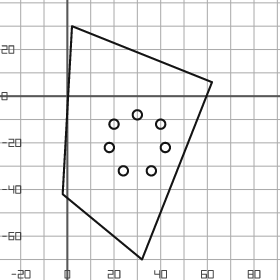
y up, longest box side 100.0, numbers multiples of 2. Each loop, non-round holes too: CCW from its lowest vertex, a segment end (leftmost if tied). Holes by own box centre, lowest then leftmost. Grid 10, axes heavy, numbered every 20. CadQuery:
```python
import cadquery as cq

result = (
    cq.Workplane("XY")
    .moveTo(32.0, -70.0)
    .lineTo(62.0, 6.0)
    .lineTo(2.0, 30.0)
    .lineTo(-2.0, -42.0)
    .close()
    .moveTo(24.0, -32.0)
    .circle(2.0)
    .moveTo(36.0, -32.0)
    .circle(2.0)
    .moveTo(18.0, -22.0)
    .circle(2.0)
    .moveTo(42.0, -22.0)
    .circle(2.0)
    .moveTo(20.0, -12.0)
    .circle(2.0)
    .moveTo(40.0, -12.0)
    .circle(2.0)
    .moveTo(30.0, -8.0)
    .circle(2.0)
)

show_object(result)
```